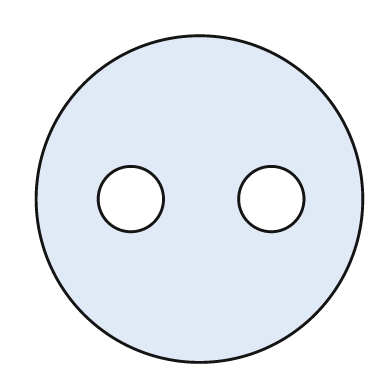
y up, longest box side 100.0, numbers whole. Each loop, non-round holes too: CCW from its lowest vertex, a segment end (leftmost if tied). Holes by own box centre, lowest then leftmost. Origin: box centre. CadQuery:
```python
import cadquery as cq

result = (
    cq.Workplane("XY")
    .moveTo(0.0, 0.0)
    .circle(50.0)
    .moveTo(-21.0, 0.0)
    .circle(10.0)
    .moveTo(22.0, 0.0)
    .circle(10.0)
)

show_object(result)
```